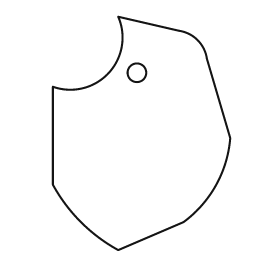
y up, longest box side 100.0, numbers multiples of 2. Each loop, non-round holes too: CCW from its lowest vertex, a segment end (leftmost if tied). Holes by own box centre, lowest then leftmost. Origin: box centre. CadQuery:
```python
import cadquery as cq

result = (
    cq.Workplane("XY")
    .moveTo(-10.0, -50.0)
    .lineTo(18.0, -38.0)
    .threePointArc((32.0, -22.0), (38.0, -2.0))
    .lineTo(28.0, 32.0)
    .threePointArc((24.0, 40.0), (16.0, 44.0))
    .lineTo(-10.0, 50.0)
    .threePointArc((-14.0, 26.0), (-38.0, 20.0))
    .lineTo(-38.0, -22.0)
    .threePointArc((-26.0, -38.0), (-10.0, -50.0))
    .close()
    .moveTo(-2.0, 26.0)
    .circle(4.0)
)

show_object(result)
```